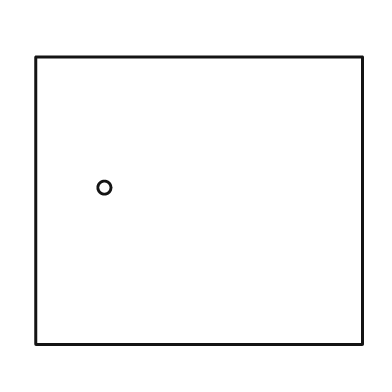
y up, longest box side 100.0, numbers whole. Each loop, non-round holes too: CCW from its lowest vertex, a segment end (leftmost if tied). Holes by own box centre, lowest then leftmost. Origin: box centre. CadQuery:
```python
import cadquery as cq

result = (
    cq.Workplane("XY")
    .moveTo(-50.0, -44.0)
    .lineTo(50.0, -44.0)
    .lineTo(50.0, 44.0)
    .lineTo(-50.0, 44.0)
    .close()
    .moveTo(-29.0, 4.0)
    .circle(2.0)
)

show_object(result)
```